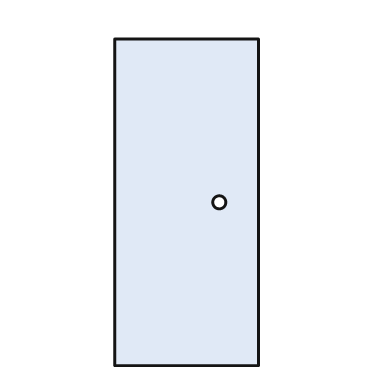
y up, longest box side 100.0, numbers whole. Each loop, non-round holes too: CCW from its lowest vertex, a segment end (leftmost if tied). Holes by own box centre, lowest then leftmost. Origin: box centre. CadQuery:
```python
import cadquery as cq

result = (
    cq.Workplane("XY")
    .moveTo(-22.0, -50.0)
    .lineTo(22.0, -50.0)
    .lineTo(22.0, 50.0)
    .lineTo(-22.0, 50.0)
    .close()
    .moveTo(10.0, 0.0)
    .circle(2.0)
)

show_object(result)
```